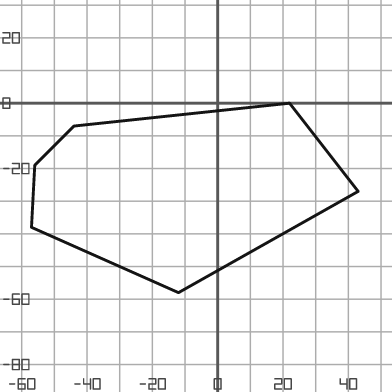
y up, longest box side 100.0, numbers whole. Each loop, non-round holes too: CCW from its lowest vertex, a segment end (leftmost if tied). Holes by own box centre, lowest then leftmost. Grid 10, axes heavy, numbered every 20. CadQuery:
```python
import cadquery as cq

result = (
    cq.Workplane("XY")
    .moveTo(-12.0, -58.0)
    .lineTo(43.0, -27.0)
    .lineTo(22.0, 0.0)
    .lineTo(-44.0, -7.0)
    .lineTo(-56.0, -19.0)
    .lineTo(-57.0, -38.0)
    .close()
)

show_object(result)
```